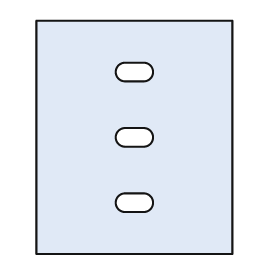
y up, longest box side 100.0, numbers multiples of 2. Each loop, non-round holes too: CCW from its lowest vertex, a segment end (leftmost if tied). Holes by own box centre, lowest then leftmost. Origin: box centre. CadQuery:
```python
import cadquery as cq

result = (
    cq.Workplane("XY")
    .moveTo(-42.0, -50.0)
    .lineTo(42.0, -50.0)
    .lineTo(42.0, 50.0)
    .lineTo(-42.0, 50.0)
    .close()
    .moveTo(-4.0, -32.0)
    .lineTo(4.0, -32.0)
    .threePointArc((8.0, -28.0), (4.0, -24.0))
    .lineTo(-4.0, -24.0)
    .threePointArc((-8.0, -28.0), (-4.0, -32.0))
    .close()
    .moveTo(-4.0, -4.0)
    .lineTo(4.0, -4.0)
    .threePointArc((8.0, 0.0), (4.0, 4.0))
    .lineTo(-4.0, 4.0)
    .threePointArc((-8.0, 0.0), (-4.0, -4.0))
    .close()
    .moveTo(-4.0, 24.0)
    .lineTo(4.0, 24.0)
    .threePointArc((8.0, 28.0), (4.0, 32.0))
    .lineTo(-4.0, 32.0)
    .threePointArc((-8.0, 28.0), (-4.0, 24.0))
    .close()
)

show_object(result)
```